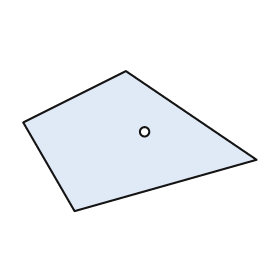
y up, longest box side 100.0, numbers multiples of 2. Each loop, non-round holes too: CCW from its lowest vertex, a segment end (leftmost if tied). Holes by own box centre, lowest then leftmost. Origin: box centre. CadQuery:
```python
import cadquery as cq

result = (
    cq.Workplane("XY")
    .moveTo(-28.0, -30.0)
    .lineTo(50.0, -8.0)
    .lineTo(-6.0, 30.0)
    .lineTo(-50.0, 8.0)
    .close()
    .moveTo(2.0, 4.0)
    .circle(2.0)
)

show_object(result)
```